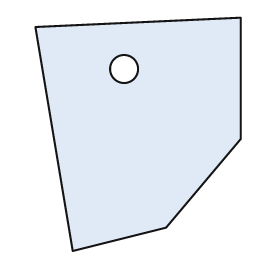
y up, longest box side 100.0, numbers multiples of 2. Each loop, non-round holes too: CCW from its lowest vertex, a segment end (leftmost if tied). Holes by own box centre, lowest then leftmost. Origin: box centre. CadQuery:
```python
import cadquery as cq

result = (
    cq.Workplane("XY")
    .moveTo(-28.0, -50.0)
    .lineTo(12.0, -40.0)
    .lineTo(44.0, -2.0)
    .lineTo(44.0, 50.0)
    .lineTo(-44.0, 46.0)
    .close()
    .moveTo(-6.0, 28.0)
    .circle(6.0)
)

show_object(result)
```